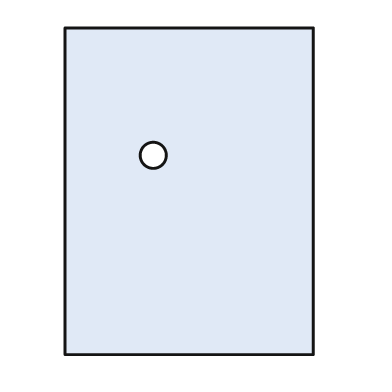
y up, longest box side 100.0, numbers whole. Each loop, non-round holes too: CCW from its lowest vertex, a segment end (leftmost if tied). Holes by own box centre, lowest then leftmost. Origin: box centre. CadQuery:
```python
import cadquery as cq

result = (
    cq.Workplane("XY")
    .moveTo(-38.0, -50.0)
    .lineTo(38.0, -50.0)
    .lineTo(38.0, 50.0)
    .lineTo(-38.0, 50.0)
    .close()
    .moveTo(-11.0, 11.0)
    .circle(4.0)
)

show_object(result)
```